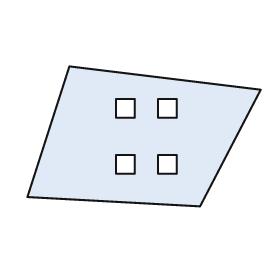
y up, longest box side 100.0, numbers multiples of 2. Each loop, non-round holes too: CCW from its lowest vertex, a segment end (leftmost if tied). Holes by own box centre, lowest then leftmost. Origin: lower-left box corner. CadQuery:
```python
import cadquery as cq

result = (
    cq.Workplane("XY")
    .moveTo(74.0, 0.0)
    .lineTo(100.0, 50.0)
    .lineTo(18.0, 60.0)
    .lineTo(0.0, 4.0)
    .close()
    .moveTo(38.0, 14.0)
    .lineTo(46.0, 14.0)
    .lineTo(46.0, 22.0)
    .lineTo(38.0, 22.0)
    .close()
    .moveTo(56.0, 14.0)
    .lineTo(64.0, 14.0)
    .lineTo(64.0, 22.0)
    .lineTo(56.0, 22.0)
    .close()
    .moveTo(38.0, 38.0)
    .lineTo(46.0, 38.0)
    .lineTo(46.0, 46.0)
    .lineTo(38.0, 46.0)
    .close()
    .moveTo(56.0, 38.0)
    .lineTo(64.0, 38.0)
    .lineTo(64.0, 46.0)
    .lineTo(56.0, 46.0)
    .close()
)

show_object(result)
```